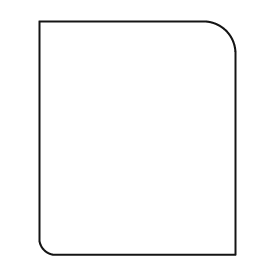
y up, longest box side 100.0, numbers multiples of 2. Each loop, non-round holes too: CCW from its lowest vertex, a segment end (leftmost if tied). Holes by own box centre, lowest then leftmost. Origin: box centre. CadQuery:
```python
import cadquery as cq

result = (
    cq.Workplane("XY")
    .moveTo(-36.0, -50.0)
    .lineTo(42.0, -50.0)
    .lineTo(42.0, 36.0)
    .threePointArc((38.0, 46.0), (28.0, 50.0))
    .lineTo(-42.0, 50.0)
    .lineTo(-42.0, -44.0)
    .threePointArc((-40.0, -48.0), (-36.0, -50.0))
    .close()
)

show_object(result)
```